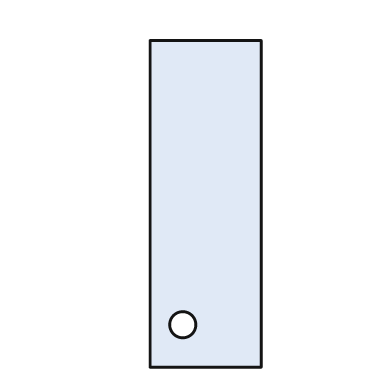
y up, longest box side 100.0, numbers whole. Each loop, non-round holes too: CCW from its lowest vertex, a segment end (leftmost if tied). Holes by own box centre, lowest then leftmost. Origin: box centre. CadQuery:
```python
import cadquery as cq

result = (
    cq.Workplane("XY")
    .moveTo(-17.0, -50.0)
    .lineTo(17.0, -50.0)
    .lineTo(17.0, 50.0)
    .lineTo(-17.0, 50.0)
    .close()
    .moveTo(-7.0, -37.0)
    .circle(4.0)
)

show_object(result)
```